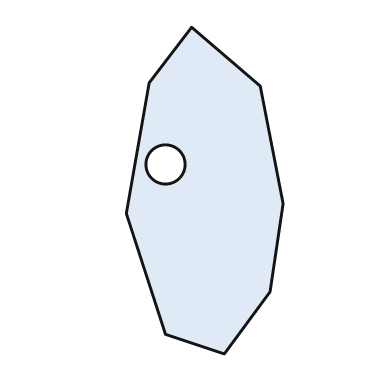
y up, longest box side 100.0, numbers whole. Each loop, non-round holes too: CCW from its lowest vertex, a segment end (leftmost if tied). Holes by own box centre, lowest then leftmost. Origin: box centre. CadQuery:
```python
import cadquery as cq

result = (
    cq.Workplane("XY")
    .moveTo(6.0, -50.0)
    .lineTo(20.0, -31.0)
    .lineTo(24.0, -4.0)
    .lineTo(17.0, 32.0)
    .lineTo(-4.0, 50.0)
    .lineTo(-17.0, 33.0)
    .lineTo(-24.0, -7.0)
    .lineTo(-12.0, -44.0)
    .close()
    .moveTo(-12.0, 8.0)
    .circle(6.0)
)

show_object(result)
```